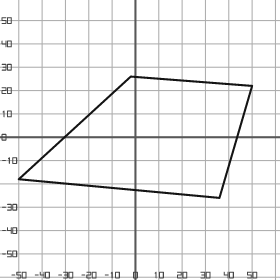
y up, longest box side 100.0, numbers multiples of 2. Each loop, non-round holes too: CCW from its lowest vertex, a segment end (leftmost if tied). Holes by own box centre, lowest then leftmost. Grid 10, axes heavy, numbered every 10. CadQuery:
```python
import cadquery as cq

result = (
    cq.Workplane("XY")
    .moveTo(36.0, -26.0)
    .lineTo(50.0, 22.0)
    .lineTo(-2.0, 26.0)
    .lineTo(-50.0, -18.0)
    .close()
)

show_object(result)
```